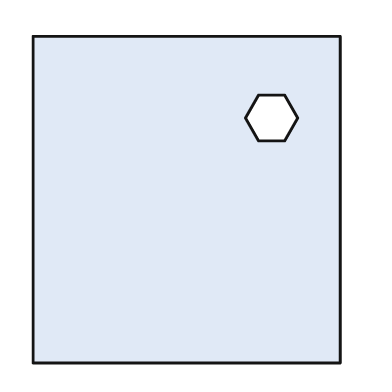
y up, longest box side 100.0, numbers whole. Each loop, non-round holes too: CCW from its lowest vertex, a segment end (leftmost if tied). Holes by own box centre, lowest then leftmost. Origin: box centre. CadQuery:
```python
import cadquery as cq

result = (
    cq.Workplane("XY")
    .moveTo(-47.0, -50.0)
    .lineTo(47.0, -50.0)
    .lineTo(47.0, 50.0)
    .lineTo(-47.0, 50.0)
    .close()
    .moveTo(22.0, 18.0)
    .lineTo(30.0, 18.0)
    .lineTo(34.0, 25.0)
    .lineTo(30.0, 32.0)
    .lineTo(22.0, 32.0)
    .lineTo(18.0, 25.0)
    .close()
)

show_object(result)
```